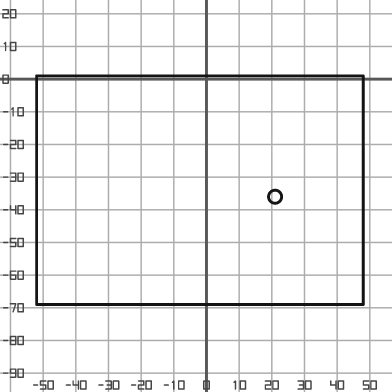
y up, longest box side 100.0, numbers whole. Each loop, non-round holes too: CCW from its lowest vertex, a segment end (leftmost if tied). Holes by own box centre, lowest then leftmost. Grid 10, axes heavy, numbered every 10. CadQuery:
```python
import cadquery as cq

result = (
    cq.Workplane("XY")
    .moveTo(-52.0, -69.0)
    .lineTo(48.0, -69.0)
    .lineTo(48.0, 1.0)
    .lineTo(-52.0, 1.0)
    .close()
    .moveTo(21.0, -36.0)
    .circle(2.0)
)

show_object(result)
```